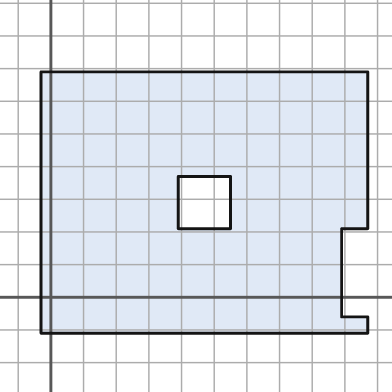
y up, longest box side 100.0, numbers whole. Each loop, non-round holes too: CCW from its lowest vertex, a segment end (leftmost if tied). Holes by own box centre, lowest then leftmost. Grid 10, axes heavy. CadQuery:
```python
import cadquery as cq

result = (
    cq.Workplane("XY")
    .moveTo(-3.0, -11.0)
    .lineTo(97.0, -11.0)
    .lineTo(97.0, -6.0)
    .lineTo(89.0, -6.0)
    .lineTo(89.0, 21.0)
    .lineTo(97.0, 21.0)
    .lineTo(97.0, 69.0)
    .lineTo(-3.0, 69.0)
    .close()
    .moveTo(39.0, 21.0)
    .lineTo(55.0, 21.0)
    .lineTo(55.0, 37.0)
    .lineTo(39.0, 37.0)
    .close()
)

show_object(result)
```